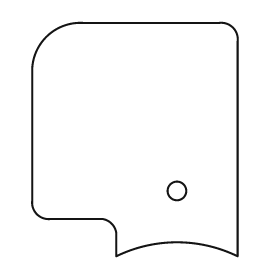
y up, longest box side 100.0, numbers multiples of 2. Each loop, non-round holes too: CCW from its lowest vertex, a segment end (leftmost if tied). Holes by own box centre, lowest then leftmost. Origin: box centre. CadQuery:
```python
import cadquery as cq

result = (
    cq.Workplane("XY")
    .moveTo(-8.0, -50.0)
    .threePointArc((18.0, -44.0), (44.0, -50.0))
    .lineTo(44.0, 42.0)
    .threePointArc((42.0, 48.0), (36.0, 50.0))
    .lineTo(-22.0, 50.0)
    .threePointArc((-38.0, 44.0), (-44.0, 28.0))
    .lineTo(-44.0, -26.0)
    .threePointArc((-42.0, -32.0), (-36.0, -34.0))
    .lineTo(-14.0, -34.0)
    .threePointArc((-10.0, -36.0), (-8.0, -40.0))
    .close()
    .moveTo(18.0, -22.0)
    .circle(4.0)
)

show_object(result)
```